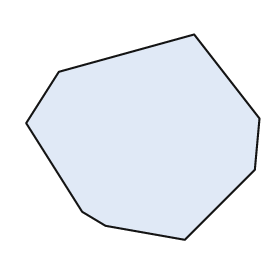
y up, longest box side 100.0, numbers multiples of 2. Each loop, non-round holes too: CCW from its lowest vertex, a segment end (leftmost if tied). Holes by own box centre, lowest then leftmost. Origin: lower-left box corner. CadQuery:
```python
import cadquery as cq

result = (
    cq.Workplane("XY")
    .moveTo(68.0, 0.0)
    .lineTo(98.0, 30.0)
    .lineTo(100.0, 52.0)
    .lineTo(72.0, 88.0)
    .lineTo(14.0, 72.0)
    .lineTo(0.0, 50.0)
    .lineTo(24.0, 12.0)
    .lineTo(34.0, 6.0)
    .close()
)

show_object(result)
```